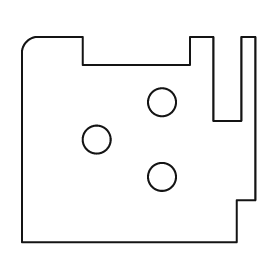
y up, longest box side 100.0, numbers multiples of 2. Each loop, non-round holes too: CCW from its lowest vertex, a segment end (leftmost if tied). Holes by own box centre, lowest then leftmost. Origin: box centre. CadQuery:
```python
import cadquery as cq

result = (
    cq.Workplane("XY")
    .moveTo(-50.0, -44.0)
    .lineTo(42.0, -44.0)
    .lineTo(42.0, -26.0)
    .lineTo(50.0, -26.0)
    .lineTo(50.0, 44.0)
    .lineTo(44.0, 44.0)
    .lineTo(44.0, 8.0)
    .lineTo(32.0, 8.0)
    .lineTo(32.0, 44.0)
    .lineTo(22.0, 44.0)
    .lineTo(22.0, 32.0)
    .lineTo(-24.0, 32.0)
    .lineTo(-24.0, 44.0)
    .lineTo(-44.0, 44.0)
    .threePointArc((-48.0, 42.0), (-50.0, 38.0))
    .close()
    .moveTo(10.0, -16.0)
    .circle(6.0)
    .moveTo(-18.0, 0.0)
    .circle(6.0)
    .moveTo(10.0, 16.0)
    .circle(6.0)
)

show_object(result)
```